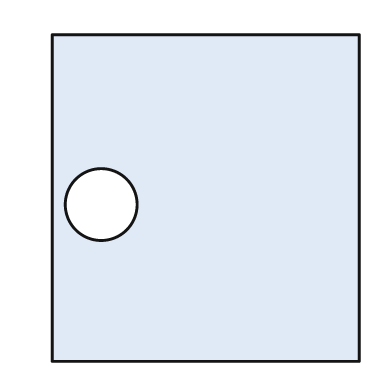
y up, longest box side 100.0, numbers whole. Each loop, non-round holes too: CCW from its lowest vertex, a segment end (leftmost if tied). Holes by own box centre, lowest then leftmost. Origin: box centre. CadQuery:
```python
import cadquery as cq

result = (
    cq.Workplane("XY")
    .moveTo(-47.0, -50.0)
    .lineTo(47.0, -50.0)
    .lineTo(47.0, 50.0)
    .lineTo(-47.0, 50.0)
    .close()
    .moveTo(-32.0, -2.0)
    .circle(11.0)
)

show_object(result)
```